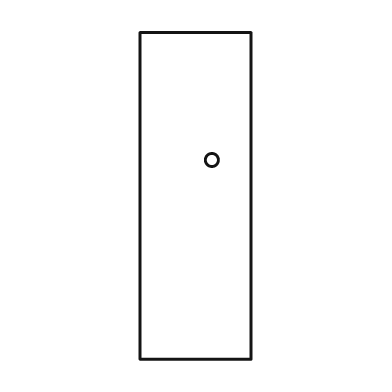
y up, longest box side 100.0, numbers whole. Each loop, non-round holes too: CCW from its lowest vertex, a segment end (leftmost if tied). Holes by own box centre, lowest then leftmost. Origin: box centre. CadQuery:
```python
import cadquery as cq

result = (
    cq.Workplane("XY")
    .moveTo(-17.0, -50.0)
    .lineTo(17.0, -50.0)
    .lineTo(17.0, 50.0)
    .lineTo(-17.0, 50.0)
    .close()
    .moveTo(5.0, 11.0)
    .circle(2.0)
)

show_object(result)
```